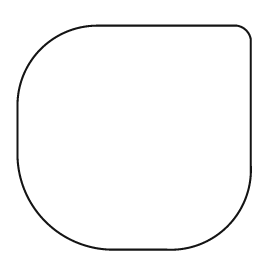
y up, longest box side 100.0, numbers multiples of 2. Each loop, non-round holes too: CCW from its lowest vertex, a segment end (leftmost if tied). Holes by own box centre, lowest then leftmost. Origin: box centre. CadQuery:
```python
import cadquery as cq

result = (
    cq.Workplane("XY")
    .moveTo(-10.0, -48.0)
    .lineTo(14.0, -48.0)
    .threePointArc((40.0, -38.0), (50.0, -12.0))
    .lineTo(50.0, 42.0)
    .threePointArc((48.0, 46.0), (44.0, 48.0))
    .lineTo(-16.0, 48.0)
    .threePointArc((-40.0, 38.0), (-50.0, 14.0))
    .lineTo(-50.0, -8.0)
    .threePointArc((-38.0, -36.0), (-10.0, -48.0))
    .close()
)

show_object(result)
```